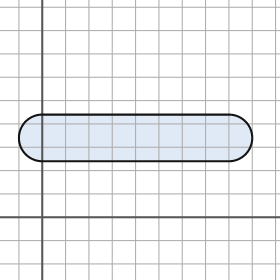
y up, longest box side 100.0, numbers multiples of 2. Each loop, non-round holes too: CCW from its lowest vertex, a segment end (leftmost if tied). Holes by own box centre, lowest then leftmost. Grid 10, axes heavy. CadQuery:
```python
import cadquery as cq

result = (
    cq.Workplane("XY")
    .moveTo(0.0, 24.0)
    .lineTo(80.0, 24.0)
    .threePointArc((90.0, 34.0), (80.0, 44.0))
    .lineTo(0.0, 44.0)
    .threePointArc((-10.0, 34.0), (0.0, 24.0))
    .close()
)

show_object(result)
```